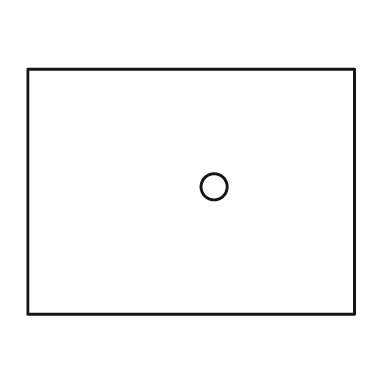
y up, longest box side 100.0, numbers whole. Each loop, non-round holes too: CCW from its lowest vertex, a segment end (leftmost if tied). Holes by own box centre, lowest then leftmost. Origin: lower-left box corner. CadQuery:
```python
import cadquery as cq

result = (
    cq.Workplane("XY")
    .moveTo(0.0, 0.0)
    .lineTo(100.0, 0.0)
    .lineTo(100.0, 75.0)
    .lineTo(0.0, 75.0)
    .close()
    .moveTo(57.0, 39.0)
    .circle(4.0)
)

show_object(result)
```